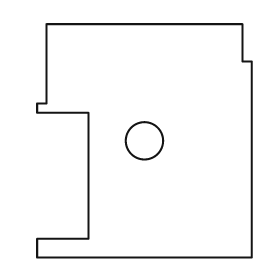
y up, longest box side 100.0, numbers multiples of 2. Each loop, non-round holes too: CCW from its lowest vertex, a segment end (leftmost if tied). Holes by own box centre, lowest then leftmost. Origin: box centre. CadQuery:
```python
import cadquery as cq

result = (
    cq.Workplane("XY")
    .moveTo(-46.0, -50.0)
    .lineTo(46.0, -50.0)
    .lineTo(46.0, 34.0)
    .lineTo(42.0, 34.0)
    .lineTo(42.0, 50.0)
    .lineTo(-42.0, 50.0)
    .lineTo(-42.0, 16.0)
    .lineTo(-46.0, 16.0)
    .lineTo(-46.0, 12.0)
    .lineTo(-24.0, 12.0)
    .lineTo(-24.0, -42.0)
    .lineTo(-46.0, -42.0)
    .close()
    .moveTo(0.0, 0.0)
    .circle(8.0)
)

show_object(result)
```